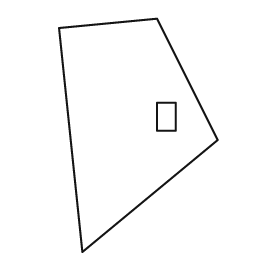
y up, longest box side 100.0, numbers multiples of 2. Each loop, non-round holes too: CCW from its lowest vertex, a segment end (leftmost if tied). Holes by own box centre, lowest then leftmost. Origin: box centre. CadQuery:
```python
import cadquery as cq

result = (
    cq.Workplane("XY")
    .moveTo(-24.0, -50.0)
    .lineTo(34.0, -2.0)
    .lineTo(8.0, 50.0)
    .lineTo(-34.0, 46.0)
    .close()
    .moveTo(8.0, 2.0)
    .lineTo(16.0, 2.0)
    .lineTo(16.0, 14.0)
    .lineTo(8.0, 14.0)
    .close()
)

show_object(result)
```